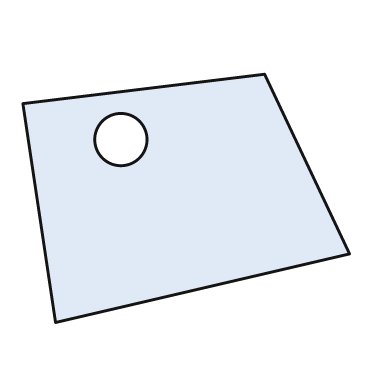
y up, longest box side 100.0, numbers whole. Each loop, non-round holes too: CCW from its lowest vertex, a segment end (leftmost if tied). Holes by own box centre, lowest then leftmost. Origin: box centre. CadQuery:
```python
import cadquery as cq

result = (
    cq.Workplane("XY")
    .moveTo(-40.0, -38.0)
    .lineTo(50.0, -17.0)
    .lineTo(24.0, 38.0)
    .lineTo(-50.0, 29.0)
    .close()
    .moveTo(-20.0, 18.0)
    .circle(8.0)
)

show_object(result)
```